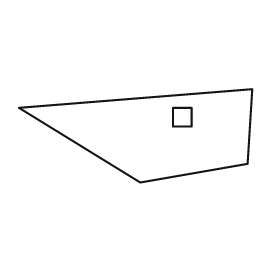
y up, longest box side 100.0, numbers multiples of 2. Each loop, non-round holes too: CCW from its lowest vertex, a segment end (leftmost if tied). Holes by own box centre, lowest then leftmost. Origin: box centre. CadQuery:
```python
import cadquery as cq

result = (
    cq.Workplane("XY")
    .moveTo(2.0, -20.0)
    .lineTo(48.0, -12.0)
    .lineTo(50.0, 20.0)
    .lineTo(-50.0, 12.0)
    .close()
    .moveTo(16.0, 4.0)
    .lineTo(24.0, 4.0)
    .lineTo(24.0, 12.0)
    .lineTo(16.0, 12.0)
    .close()
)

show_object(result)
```